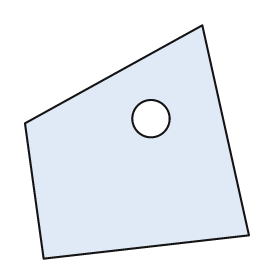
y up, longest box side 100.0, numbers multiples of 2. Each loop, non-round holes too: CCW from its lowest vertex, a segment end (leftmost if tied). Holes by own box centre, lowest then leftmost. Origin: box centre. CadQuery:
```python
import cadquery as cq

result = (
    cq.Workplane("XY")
    .moveTo(-40.0, -50.0)
    .lineTo(48.0, -40.0)
    .lineTo(28.0, 50.0)
    .lineTo(-48.0, 8.0)
    .close()
    .moveTo(6.0, 10.0)
    .circle(8.0)
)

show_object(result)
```